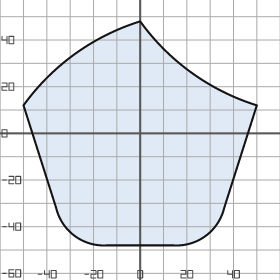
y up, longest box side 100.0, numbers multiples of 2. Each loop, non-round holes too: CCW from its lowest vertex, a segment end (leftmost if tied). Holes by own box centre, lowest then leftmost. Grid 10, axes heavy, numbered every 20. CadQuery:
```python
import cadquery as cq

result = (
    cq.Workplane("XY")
    .moveTo(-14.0, -48.0)
    .lineTo(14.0, -48.0)
    .threePointArc((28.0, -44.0), (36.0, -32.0))
    .lineTo(50.0, 12.0)
    .threePointArc((22.0, 26.0), (0.0, 48.0))
    .threePointArc((-28.0, 34.0), (-50.0, 12.0))
    .lineTo(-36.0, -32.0)
    .threePointArc((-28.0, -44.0), (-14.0, -48.0))
    .close()
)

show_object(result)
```